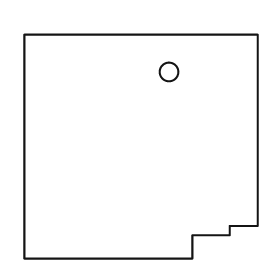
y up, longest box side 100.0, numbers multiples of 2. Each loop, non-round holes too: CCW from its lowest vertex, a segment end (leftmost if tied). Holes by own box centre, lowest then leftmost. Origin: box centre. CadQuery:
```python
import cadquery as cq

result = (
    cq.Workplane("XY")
    .moveTo(-50.0, -48.0)
    .lineTo(22.0, -48.0)
    .lineTo(22.0, -38.0)
    .lineTo(38.0, -38.0)
    .lineTo(38.0, -34.0)
    .lineTo(50.0, -34.0)
    .lineTo(50.0, 48.0)
    .lineTo(-50.0, 48.0)
    .close()
    .moveTo(12.0, 32.0)
    .circle(4.0)
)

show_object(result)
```